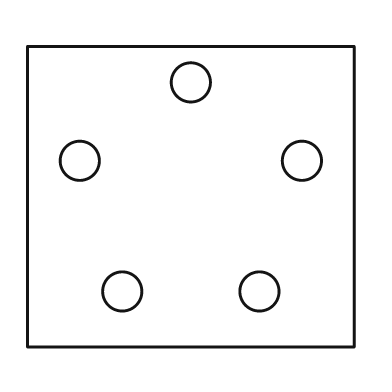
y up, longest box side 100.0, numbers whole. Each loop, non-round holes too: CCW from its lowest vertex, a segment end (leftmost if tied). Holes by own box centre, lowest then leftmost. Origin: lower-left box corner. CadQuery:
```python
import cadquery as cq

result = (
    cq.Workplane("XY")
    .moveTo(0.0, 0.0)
    .lineTo(100.0, 0.0)
    .lineTo(100.0, 92.0)
    .lineTo(0.0, 92.0)
    .close()
    .moveTo(29.0, 17.0)
    .circle(6.0)
    .moveTo(71.0, 17.0)
    .circle(6.0)
    .moveTo(16.0, 57.0)
    .circle(6.0)
    .moveTo(84.0, 57.0)
    .circle(6.0)
    .moveTo(50.0, 81.0)
    .circle(6.0)
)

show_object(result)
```